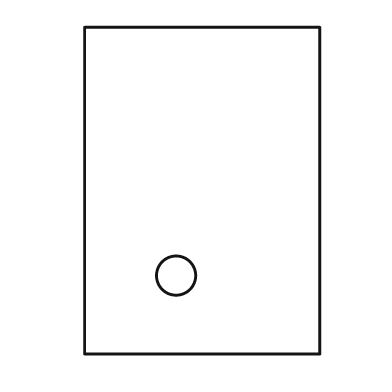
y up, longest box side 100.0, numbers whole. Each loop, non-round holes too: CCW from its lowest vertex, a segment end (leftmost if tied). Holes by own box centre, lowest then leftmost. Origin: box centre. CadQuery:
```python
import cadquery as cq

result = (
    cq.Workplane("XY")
    .moveTo(-36.0, -50.0)
    .lineTo(36.0, -50.0)
    .lineTo(36.0, 50.0)
    .lineTo(-36.0, 50.0)
    .close()
    .moveTo(-8.0, -26.0)
    .circle(6.0)
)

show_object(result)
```